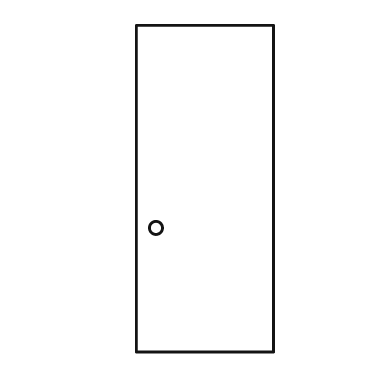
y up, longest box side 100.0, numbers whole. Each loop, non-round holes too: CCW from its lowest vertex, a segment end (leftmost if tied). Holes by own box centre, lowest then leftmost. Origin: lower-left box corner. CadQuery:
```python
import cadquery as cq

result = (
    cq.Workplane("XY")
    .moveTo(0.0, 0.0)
    .lineTo(42.0, 0.0)
    .lineTo(42.0, 100.0)
    .lineTo(0.0, 100.0)
    .close()
    .moveTo(6.0, 38.0)
    .circle(2.0)
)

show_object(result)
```